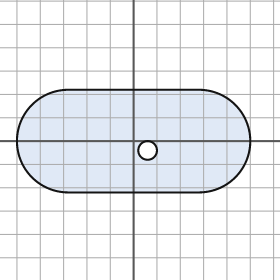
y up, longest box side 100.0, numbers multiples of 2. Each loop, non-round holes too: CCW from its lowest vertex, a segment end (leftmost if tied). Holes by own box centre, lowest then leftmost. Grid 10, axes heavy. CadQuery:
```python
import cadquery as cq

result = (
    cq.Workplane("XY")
    .moveTo(-28.0, -22.0)
    .lineTo(28.0, -22.0)
    .threePointArc((50.0, 0.0), (28.0, 22.0))
    .lineTo(-28.0, 22.0)
    .threePointArc((-50.0, 0.0), (-28.0, -22.0))
    .close()
    .moveTo(6.0, -4.0)
    .circle(4.0)
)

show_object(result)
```